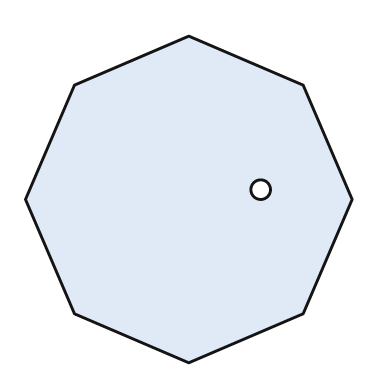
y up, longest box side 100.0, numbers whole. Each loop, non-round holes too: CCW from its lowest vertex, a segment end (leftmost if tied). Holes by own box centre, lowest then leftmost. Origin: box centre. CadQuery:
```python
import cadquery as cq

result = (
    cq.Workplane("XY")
    .moveTo(0.0, -50.0)
    .lineTo(35.0, -35.0)
    .lineTo(50.0, 0.0)
    .lineTo(35.0, 35.0)
    .lineTo(0.0, 50.0)
    .lineTo(-35.0, 35.0)
    .lineTo(-50.0, 0.0)
    .lineTo(-35.0, -35.0)
    .close()
    .moveTo(22.0, 3.0)
    .circle(3.0)
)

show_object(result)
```